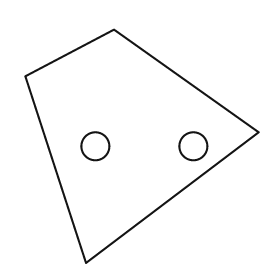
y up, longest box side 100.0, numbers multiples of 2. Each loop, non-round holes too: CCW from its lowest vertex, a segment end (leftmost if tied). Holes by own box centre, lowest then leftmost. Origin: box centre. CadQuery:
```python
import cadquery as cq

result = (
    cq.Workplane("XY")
    .moveTo(-24.0, -50.0)
    .lineTo(50.0, 6.0)
    .lineTo(-12.0, 50.0)
    .lineTo(-50.0, 30.0)
    .close()
    .moveTo(-20.0, 0.0)
    .circle(6.0)
    .moveTo(22.0, 0.0)
    .circle(6.0)
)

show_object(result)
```